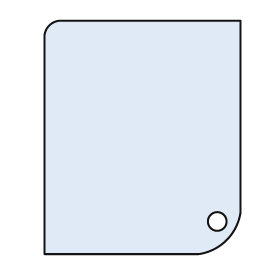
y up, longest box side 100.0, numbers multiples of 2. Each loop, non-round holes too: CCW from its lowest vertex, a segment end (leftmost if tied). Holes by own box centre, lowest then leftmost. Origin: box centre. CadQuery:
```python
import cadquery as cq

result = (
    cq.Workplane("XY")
    .moveTo(-42.0, -50.0)
    .lineTo(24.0, -50.0)
    .threePointArc((36.0, -44.0), (42.0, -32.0))
    .lineTo(42.0, 50.0)
    .lineTo(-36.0, 50.0)
    .threePointArc((-40.0, 48.0), (-42.0, 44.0))
    .close()
    .moveTo(32.0, -36.0)
    .circle(4.0)
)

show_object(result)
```